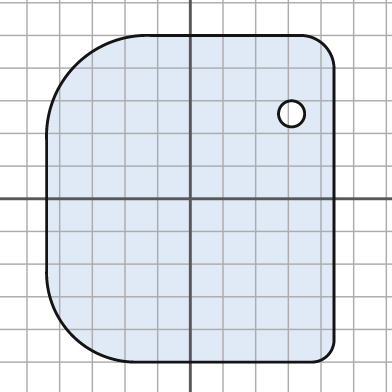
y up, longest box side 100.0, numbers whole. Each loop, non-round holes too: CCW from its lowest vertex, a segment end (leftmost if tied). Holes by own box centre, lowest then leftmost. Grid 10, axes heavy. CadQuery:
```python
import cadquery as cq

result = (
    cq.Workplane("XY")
    .moveTo(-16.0, -50.0)
    .lineTo(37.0, -50.0)
    .threePointArc((42.0, -48.0), (44.0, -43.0))
    .lineTo(44.0, 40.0)
    .threePointArc((41.0, 47.0), (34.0, 50.0))
    .lineTo(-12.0, 50.0)
    .threePointArc((-35.0, 41.0), (-44.0, 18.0))
    .lineTo(-44.0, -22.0)
    .threePointArc((-36.0, -42.0), (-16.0, -50.0))
    .close()
    .moveTo(31.0, 26.0)
    .circle(4.0)
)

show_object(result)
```